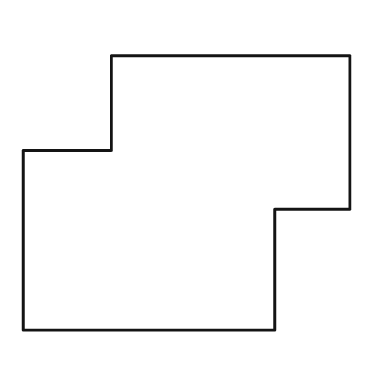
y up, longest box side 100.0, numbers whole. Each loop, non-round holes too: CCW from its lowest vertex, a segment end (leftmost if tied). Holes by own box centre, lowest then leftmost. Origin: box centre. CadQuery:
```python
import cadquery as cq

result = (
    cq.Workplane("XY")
    .moveTo(-50.0, -42.0)
    .lineTo(27.0, -42.0)
    .lineTo(27.0, -5.0)
    .lineTo(50.0, -5.0)
    .lineTo(50.0, 42.0)
    .lineTo(-23.0, 42.0)
    .lineTo(-23.0, 13.0)
    .lineTo(-50.0, 13.0)
    .close()
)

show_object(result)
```